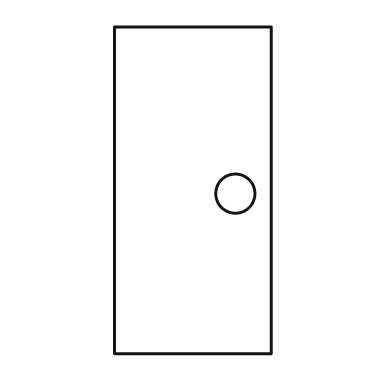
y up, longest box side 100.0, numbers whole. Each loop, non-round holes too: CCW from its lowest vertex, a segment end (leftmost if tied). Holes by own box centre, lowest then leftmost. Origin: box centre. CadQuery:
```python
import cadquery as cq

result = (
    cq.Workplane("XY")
    .moveTo(-24.0, -50.0)
    .lineTo(24.0, -50.0)
    .lineTo(24.0, 50.0)
    .lineTo(-24.0, 50.0)
    .close()
    .moveTo(13.0, -1.0)
    .circle(6.0)
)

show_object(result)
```